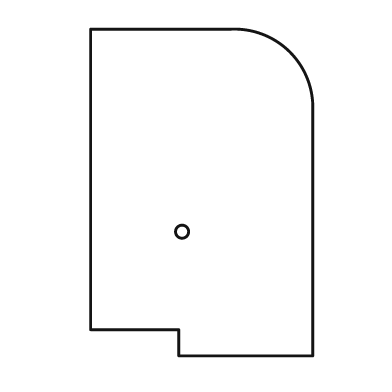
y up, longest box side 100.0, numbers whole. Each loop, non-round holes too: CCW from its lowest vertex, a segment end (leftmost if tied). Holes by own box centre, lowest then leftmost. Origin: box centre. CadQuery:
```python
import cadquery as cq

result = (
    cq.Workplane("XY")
    .moveTo(-7.0, -50.0)
    .lineTo(34.0, -50.0)
    .lineTo(34.0, 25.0)
    .threePointArc((27.0, 43.0), (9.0, 50.0))
    .lineTo(-34.0, 50.0)
    .lineTo(-34.0, -42.0)
    .lineTo(-7.0, -42.0)
    .close()
    .moveTo(-6.0, -12.0)
    .circle(2.0)
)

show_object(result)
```